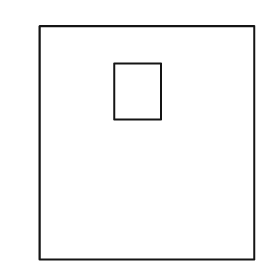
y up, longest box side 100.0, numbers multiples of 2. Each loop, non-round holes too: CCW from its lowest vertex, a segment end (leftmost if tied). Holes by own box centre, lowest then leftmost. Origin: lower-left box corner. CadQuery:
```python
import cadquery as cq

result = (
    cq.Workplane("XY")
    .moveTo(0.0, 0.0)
    .lineTo(92.0, 0.0)
    .lineTo(92.0, 100.0)
    .lineTo(0.0, 100.0)
    .close()
    .moveTo(32.0, 60.0)
    .lineTo(52.0, 60.0)
    .lineTo(52.0, 84.0)
    .lineTo(32.0, 84.0)
    .close()
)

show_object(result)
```